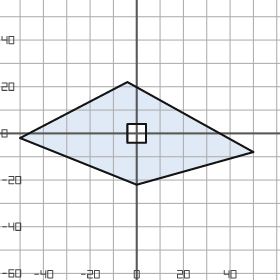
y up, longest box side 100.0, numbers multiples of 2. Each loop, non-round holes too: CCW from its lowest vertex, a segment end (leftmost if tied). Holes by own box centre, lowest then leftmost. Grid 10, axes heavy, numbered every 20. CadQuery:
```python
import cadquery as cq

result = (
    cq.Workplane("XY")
    .moveTo(0.0, -22.0)
    .lineTo(50.0, -8.0)
    .lineTo(-4.0, 22.0)
    .lineTo(-50.0, -2.0)
    .close()
    .moveTo(-4.0, -4.0)
    .lineTo(4.0, -4.0)
    .lineTo(4.0, 4.0)
    .lineTo(-4.0, 4.0)
    .close()
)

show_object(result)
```